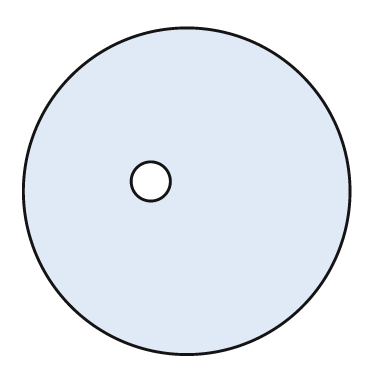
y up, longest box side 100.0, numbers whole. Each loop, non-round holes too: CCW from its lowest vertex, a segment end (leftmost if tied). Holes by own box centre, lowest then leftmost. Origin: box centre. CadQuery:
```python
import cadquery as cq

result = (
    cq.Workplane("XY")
    .moveTo(0.0, 0.0)
    .circle(50.0)
    .moveTo(-11.0, 3.0)
    .circle(6.0)
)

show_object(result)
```